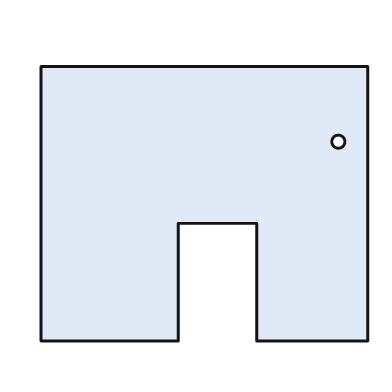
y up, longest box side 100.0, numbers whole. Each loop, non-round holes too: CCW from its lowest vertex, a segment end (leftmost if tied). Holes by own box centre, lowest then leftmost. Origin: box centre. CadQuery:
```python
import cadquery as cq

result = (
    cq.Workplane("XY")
    .moveTo(-50.0, -42.0)
    .lineTo(-8.0, -42.0)
    .lineTo(-8.0, -6.0)
    .lineTo(16.0, -6.0)
    .lineTo(16.0, -42.0)
    .lineTo(50.0, -42.0)
    .lineTo(50.0, 42.0)
    .lineTo(-50.0, 42.0)
    .close()
    .moveTo(41.0, 19.0)
    .circle(2.0)
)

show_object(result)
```